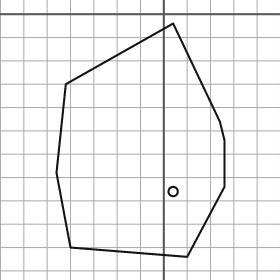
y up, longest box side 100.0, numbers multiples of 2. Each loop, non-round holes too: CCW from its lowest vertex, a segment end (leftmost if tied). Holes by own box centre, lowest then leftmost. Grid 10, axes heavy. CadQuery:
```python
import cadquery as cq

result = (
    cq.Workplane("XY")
    .moveTo(10.0, -104.0)
    .lineTo(26.0, -74.0)
    .lineTo(26.0, -54.0)
    .lineTo(24.0, -46.0)
    .lineTo(4.0, -4.0)
    .lineTo(-42.0, -30.0)
    .lineTo(-46.0, -68.0)
    .lineTo(-40.0, -100.0)
    .close()
    .moveTo(4.0, -76.0)
    .circle(2.0)
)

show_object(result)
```